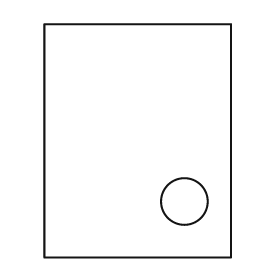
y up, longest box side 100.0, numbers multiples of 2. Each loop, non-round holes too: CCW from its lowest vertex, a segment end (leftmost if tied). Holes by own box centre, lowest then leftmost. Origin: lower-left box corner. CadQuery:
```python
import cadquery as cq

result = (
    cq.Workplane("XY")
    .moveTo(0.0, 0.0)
    .lineTo(80.0, 0.0)
    .lineTo(80.0, 100.0)
    .lineTo(0.0, 100.0)
    .close()
    .moveTo(60.0, 24.0)
    .circle(10.0)
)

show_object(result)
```